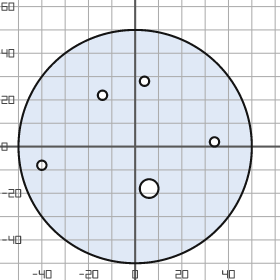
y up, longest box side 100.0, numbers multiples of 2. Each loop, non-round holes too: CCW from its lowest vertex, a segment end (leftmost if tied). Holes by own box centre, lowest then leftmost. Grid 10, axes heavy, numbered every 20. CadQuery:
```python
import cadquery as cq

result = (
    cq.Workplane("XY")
    .moveTo(0.0, 0.0)
    .circle(50.0)
    .moveTo(6.0, -18.0)
    .circle(4.0)
    .moveTo(-40.0, -8.0)
    .circle(2.0)
    .moveTo(34.0, 2.0)
    .circle(2.0)
    .moveTo(-14.0, 22.0)
    .circle(2.0)
    .moveTo(4.0, 28.0)
    .circle(2.0)
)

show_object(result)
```